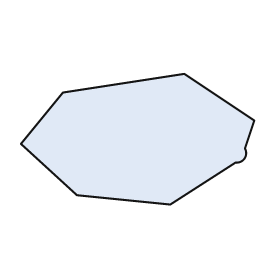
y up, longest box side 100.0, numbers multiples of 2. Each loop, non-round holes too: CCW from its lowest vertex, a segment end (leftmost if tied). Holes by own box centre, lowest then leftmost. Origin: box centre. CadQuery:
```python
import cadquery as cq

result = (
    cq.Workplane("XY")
    .moveTo(14.0, -28.0)
    .lineTo(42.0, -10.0)
    .threePointArc((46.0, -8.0), (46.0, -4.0))
    .lineTo(50.0, 8.0)
    .lineTo(20.0, 28.0)
    .lineTo(-32.0, 20.0)
    .lineTo(-50.0, -2.0)
    .lineTo(-26.0, -24.0)
    .close()
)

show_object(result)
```